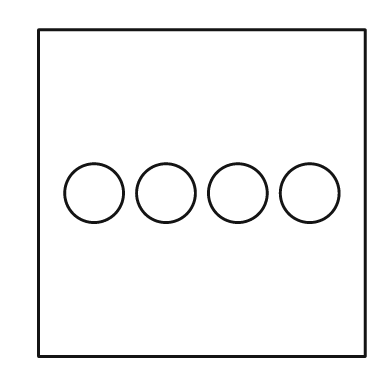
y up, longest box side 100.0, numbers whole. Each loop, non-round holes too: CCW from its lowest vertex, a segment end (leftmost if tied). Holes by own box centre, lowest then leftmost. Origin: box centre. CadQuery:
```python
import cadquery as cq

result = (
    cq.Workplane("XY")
    .moveTo(-50.0, -50.0)
    .lineTo(50.0, -50.0)
    .lineTo(50.0, 50.0)
    .lineTo(-50.0, 50.0)
    .close()
    .moveTo(-33.0, 0.0)
    .circle(9.0)
    .moveTo(-11.0, 0.0)
    .circle(9.0)
    .moveTo(11.0, 0.0)
    .circle(9.0)
    .moveTo(33.0, 0.0)
    .circle(9.0)
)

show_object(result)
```